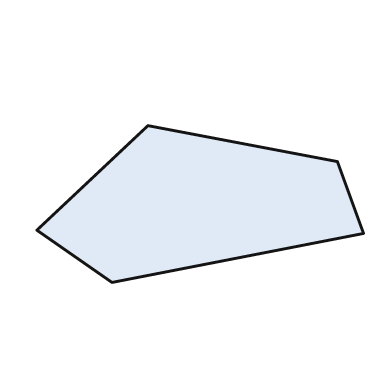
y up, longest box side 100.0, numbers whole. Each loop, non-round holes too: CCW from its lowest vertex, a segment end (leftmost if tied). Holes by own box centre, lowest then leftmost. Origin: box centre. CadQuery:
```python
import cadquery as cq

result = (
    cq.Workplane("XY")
    .moveTo(-27.0, -24.0)
    .lineTo(50.0, -9.0)
    .lineTo(42.0, 13.0)
    .lineTo(-16.0, 24.0)
    .lineTo(-50.0, -8.0)
    .close()
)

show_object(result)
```